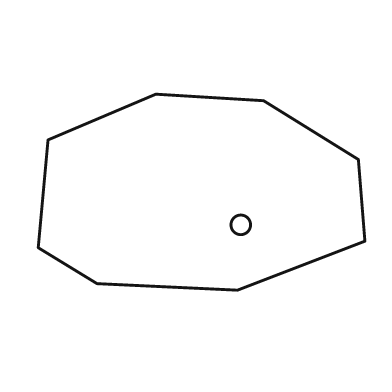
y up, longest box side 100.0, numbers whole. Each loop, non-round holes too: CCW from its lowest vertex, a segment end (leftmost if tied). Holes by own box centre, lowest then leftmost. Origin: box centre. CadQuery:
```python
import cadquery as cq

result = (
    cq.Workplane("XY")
    .moveTo(11.0, -30.0)
    .lineTo(50.0, -15.0)
    .lineTo(48.0, 10.0)
    .lineTo(19.0, 28.0)
    .lineTo(-14.0, 30.0)
    .lineTo(-47.0, 16.0)
    .lineTo(-50.0, -17.0)
    .lineTo(-32.0, -28.0)
    .close()
    .moveTo(12.0, -10.0)
    .circle(3.0)
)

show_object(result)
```